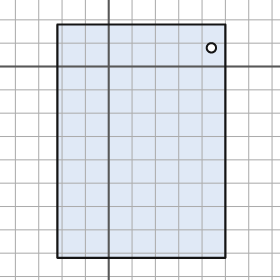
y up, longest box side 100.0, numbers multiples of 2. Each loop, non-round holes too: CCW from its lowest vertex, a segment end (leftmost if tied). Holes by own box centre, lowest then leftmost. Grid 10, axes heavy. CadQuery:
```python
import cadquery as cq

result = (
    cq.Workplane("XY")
    .moveTo(-22.0, -82.0)
    .lineTo(50.0, -82.0)
    .lineTo(50.0, 18.0)
    .lineTo(-22.0, 18.0)
    .close()
    .moveTo(44.0, 8.0)
    .circle(2.0)
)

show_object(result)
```